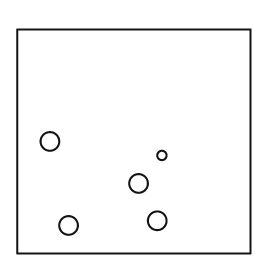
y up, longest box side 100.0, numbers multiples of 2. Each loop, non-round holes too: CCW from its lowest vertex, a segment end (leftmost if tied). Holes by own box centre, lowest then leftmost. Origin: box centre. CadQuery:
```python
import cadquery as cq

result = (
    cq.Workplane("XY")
    .moveTo(-50.0, -48.0)
    .lineTo(50.0, -48.0)
    .lineTo(50.0, 48.0)
    .lineTo(-50.0, 48.0)
    .close()
    .moveTo(-28.0, -36.0)
    .circle(4.0)
    .moveTo(10.0, -34.0)
    .circle(4.0)
    .moveTo(2.0, -18.0)
    .circle(4.0)
    .moveTo(12.0, -6.0)
    .circle(2.0)
    .moveTo(-36.0, 0.0)
    .circle(4.0)
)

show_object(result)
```